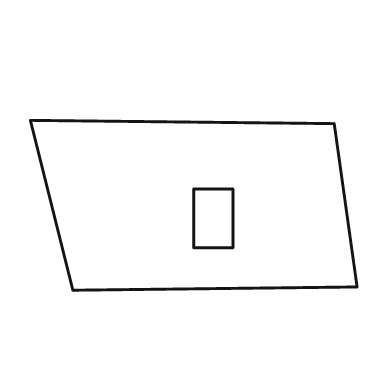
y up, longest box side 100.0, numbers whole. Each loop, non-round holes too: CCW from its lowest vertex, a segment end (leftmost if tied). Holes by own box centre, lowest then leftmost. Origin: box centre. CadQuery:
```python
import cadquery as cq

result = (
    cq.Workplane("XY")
    .moveTo(-37.0, -26.0)
    .lineTo(50.0, -25.0)
    .lineTo(43.0, 25.0)
    .lineTo(-50.0, 26.0)
    .close()
    .moveTo(0.0, -13.0)
    .lineTo(12.0, -13.0)
    .lineTo(12.0, 5.0)
    .lineTo(0.0, 5.0)
    .close()
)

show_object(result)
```